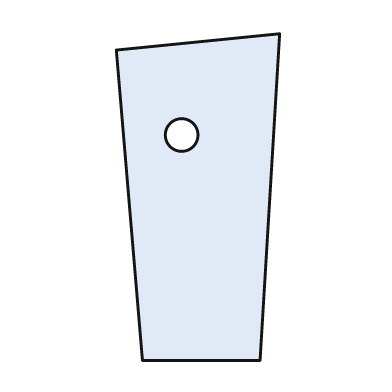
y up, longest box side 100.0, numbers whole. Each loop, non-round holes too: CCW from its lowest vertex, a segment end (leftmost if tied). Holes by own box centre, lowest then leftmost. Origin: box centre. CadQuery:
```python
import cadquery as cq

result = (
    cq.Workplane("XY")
    .moveTo(-17.0, -50.0)
    .lineTo(19.0, -50.0)
    .lineTo(25.0, 50.0)
    .lineTo(-25.0, 45.0)
    .close()
    .moveTo(-5.0, 19.0)
    .circle(5.0)
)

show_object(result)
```